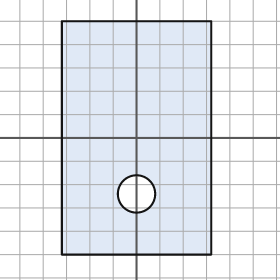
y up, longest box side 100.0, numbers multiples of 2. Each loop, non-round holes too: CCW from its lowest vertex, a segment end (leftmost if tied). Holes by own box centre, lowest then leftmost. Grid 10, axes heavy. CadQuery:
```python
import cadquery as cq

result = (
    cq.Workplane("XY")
    .moveTo(-32.0, -50.0)
    .lineTo(32.0, -50.0)
    .lineTo(32.0, 50.0)
    .lineTo(-32.0, 50.0)
    .close()
    .moveTo(0.0, -24.0)
    .circle(8.0)
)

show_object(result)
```